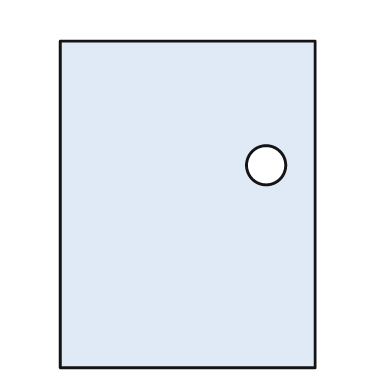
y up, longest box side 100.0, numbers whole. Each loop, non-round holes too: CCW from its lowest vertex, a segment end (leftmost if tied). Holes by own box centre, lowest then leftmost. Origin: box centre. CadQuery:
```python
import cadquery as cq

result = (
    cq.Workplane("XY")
    .moveTo(-39.0, -50.0)
    .lineTo(39.0, -50.0)
    .lineTo(39.0, 50.0)
    .lineTo(-39.0, 50.0)
    .close()
    .moveTo(24.0, 12.0)
    .circle(6.0)
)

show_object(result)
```